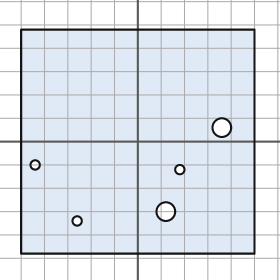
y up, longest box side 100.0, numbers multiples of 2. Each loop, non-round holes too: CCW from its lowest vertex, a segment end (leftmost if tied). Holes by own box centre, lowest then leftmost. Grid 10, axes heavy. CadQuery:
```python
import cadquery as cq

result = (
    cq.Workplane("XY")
    .moveTo(-50.0, -48.0)
    .lineTo(50.0, -48.0)
    .lineTo(50.0, 48.0)
    .lineTo(-50.0, 48.0)
    .close()
    .moveTo(-26.0, -34.0)
    .circle(2.0)
    .moveTo(12.0, -30.0)
    .circle(4.0)
    .moveTo(18.0, -12.0)
    .circle(2.0)
    .moveTo(-44.0, -10.0)
    .circle(2.0)
    .moveTo(36.0, 6.0)
    .circle(4.0)
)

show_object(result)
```